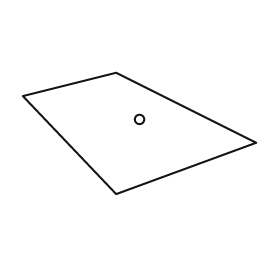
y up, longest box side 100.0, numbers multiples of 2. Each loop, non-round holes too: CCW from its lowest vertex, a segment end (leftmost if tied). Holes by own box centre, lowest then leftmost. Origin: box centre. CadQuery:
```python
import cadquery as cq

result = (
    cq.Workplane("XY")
    .moveTo(-10.0, -26.0)
    .lineTo(50.0, -4.0)
    .lineTo(-10.0, 26.0)
    .lineTo(-50.0, 16.0)
    .close()
    .moveTo(0.0, 6.0)
    .circle(2.0)
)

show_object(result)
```